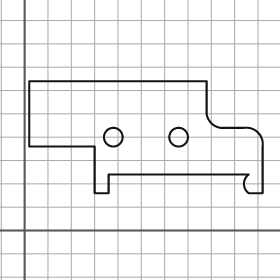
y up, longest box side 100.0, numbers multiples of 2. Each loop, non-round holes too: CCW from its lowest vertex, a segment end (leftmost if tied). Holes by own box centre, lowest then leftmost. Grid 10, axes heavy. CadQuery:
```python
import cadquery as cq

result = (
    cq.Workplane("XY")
    .moveTo(30.0, 16.0)
    .lineTo(36.0, 16.0)
    .lineTo(36.0, 24.0)
    .lineTo(96.0, 24.0)
    .threePointArc((94.0, 20.0), (96.0, 16.0))
    .lineTo(102.0, 16.0)
    .lineTo(102.0, 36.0)
    .threePointArc((100.0, 42.0), (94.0, 44.0))
    .lineTo(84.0, 44.0)
    .threePointArc((80.0, 46.0), (78.0, 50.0))
    .lineTo(78.0, 64.0)
    .lineTo(2.0, 64.0)
    .lineTo(2.0, 36.0)
    .lineTo(30.0, 36.0)
    .close()
    .moveTo(38.0, 40.0)
    .circle(4.0)
    .moveTo(66.0, 40.0)
    .circle(4.0)
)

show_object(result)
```